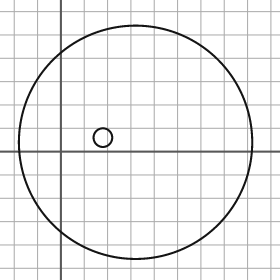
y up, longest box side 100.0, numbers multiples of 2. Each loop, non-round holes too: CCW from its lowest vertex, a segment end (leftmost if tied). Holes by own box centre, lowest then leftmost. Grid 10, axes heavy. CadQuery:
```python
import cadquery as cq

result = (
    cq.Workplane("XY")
    .moveTo(32.0, 4.0)
    .circle(50.0)
    .moveTo(18.0, 6.0)
    .circle(4.0)
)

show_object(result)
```